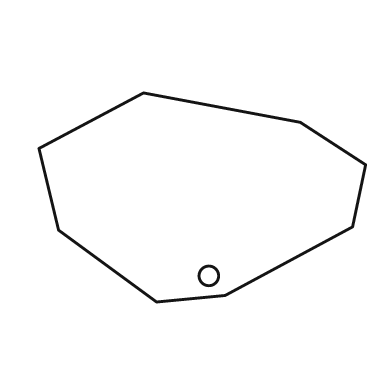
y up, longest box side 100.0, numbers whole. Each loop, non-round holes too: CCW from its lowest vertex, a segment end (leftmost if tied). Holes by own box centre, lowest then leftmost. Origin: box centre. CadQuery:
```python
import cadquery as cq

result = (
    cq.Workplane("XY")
    .moveTo(-14.0, -32.0)
    .lineTo(7.0, -30.0)
    .lineTo(46.0, -9.0)
    .lineTo(50.0, 10.0)
    .lineTo(30.0, 23.0)
    .lineTo(-18.0, 32.0)
    .lineTo(-50.0, 15.0)
    .lineTo(-44.0, -10.0)
    .close()
    .moveTo(2.0, -24.0)
    .circle(3.0)
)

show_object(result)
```